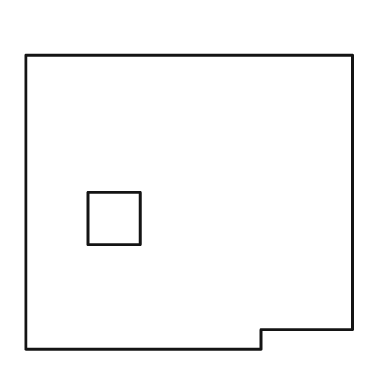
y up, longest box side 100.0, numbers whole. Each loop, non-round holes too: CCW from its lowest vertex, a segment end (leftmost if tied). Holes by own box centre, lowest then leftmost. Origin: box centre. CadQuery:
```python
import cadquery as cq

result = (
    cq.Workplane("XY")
    .moveTo(-50.0, -45.0)
    .lineTo(22.0, -45.0)
    .lineTo(22.0, -39.0)
    .lineTo(50.0, -39.0)
    .lineTo(50.0, 45.0)
    .lineTo(-50.0, 45.0)
    .close()
    .moveTo(-31.0, -13.0)
    .lineTo(-15.0, -13.0)
    .lineTo(-15.0, 3.0)
    .lineTo(-31.0, 3.0)
    .close()
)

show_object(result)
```